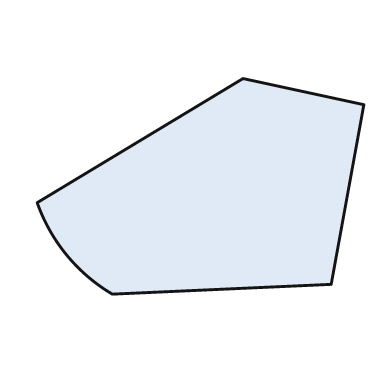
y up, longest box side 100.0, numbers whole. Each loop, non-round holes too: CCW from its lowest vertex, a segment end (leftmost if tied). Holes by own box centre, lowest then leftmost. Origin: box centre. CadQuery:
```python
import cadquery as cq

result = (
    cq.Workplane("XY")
    .moveTo(-27.0, -33.0)
    .lineTo(40.0, -30.0)
    .lineTo(50.0, 25.0)
    .lineTo(13.0, 33.0)
    .lineTo(-50.0, -5.0)
    .threePointArc((-41.0, -21.0), (-27.0, -33.0))
    .close()
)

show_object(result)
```